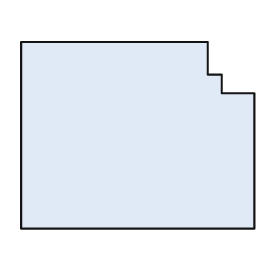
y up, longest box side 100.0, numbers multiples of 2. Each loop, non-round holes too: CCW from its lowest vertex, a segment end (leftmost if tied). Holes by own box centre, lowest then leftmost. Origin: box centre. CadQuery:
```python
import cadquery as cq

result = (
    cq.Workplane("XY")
    .moveTo(-50.0, -40.0)
    .lineTo(50.0, -40.0)
    .lineTo(50.0, 18.0)
    .lineTo(36.0, 18.0)
    .lineTo(36.0, 26.0)
    .lineTo(30.0, 26.0)
    .lineTo(30.0, 40.0)
    .lineTo(-50.0, 40.0)
    .close()
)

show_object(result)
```